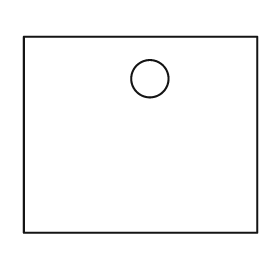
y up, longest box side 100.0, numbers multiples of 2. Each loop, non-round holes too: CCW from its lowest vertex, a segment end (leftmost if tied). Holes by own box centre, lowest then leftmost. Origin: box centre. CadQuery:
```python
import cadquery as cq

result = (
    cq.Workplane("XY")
    .moveTo(-50.0, -42.0)
    .lineTo(50.0, -42.0)
    .lineTo(50.0, 42.0)
    .lineTo(-50.0, 42.0)
    .close()
    .moveTo(4.0, 24.0)
    .circle(8.0)
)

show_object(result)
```